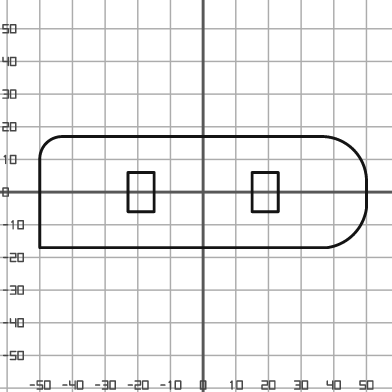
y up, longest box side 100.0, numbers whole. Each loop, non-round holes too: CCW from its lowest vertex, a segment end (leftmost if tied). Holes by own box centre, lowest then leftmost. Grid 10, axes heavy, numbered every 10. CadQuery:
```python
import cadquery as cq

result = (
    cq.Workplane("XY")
    .moveTo(-50.0, -17.0)
    .lineTo(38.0, -17.0)
    .threePointArc((46.0, -13.0), (50.0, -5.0))
    .lineTo(50.0, 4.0)
    .threePointArc((46.0, 13.0), (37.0, 17.0))
    .lineTo(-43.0, 17.0)
    .threePointArc((-48.0, 15.0), (-50.0, 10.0))
    .close()
    .moveTo(-23.0, -6.0)
    .lineTo(-15.0, -6.0)
    .lineTo(-15.0, 6.0)
    .lineTo(-23.0, 6.0)
    .close()
    .moveTo(15.0, -6.0)
    .lineTo(23.0, -6.0)
    .lineTo(23.0, 6.0)
    .lineTo(15.0, 6.0)
    .close()
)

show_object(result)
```